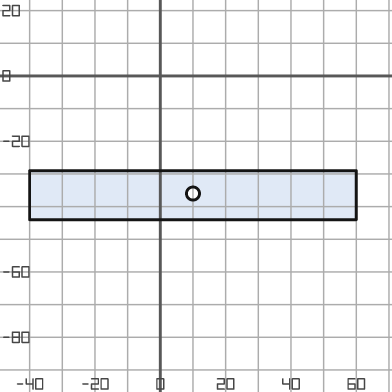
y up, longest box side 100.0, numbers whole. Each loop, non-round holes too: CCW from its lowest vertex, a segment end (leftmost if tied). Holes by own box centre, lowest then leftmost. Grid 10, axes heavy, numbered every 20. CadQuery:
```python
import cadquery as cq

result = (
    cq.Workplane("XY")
    .moveTo(-40.0, -44.0)
    .lineTo(60.0, -44.0)
    .lineTo(60.0, -29.0)
    .lineTo(-40.0, -29.0)
    .close()
    .moveTo(10.0, -36.0)
    .circle(2.0)
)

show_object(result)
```